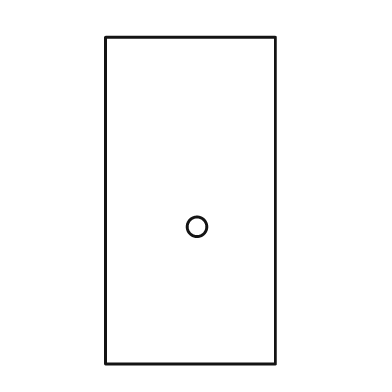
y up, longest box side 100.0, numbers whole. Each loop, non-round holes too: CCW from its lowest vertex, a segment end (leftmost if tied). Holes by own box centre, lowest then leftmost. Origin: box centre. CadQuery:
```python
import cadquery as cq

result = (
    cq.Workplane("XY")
    .moveTo(-26.0, -50.0)
    .lineTo(26.0, -50.0)
    .lineTo(26.0, 50.0)
    .lineTo(-26.0, 50.0)
    .close()
    .moveTo(2.0, -8.0)
    .circle(3.0)
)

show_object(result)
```